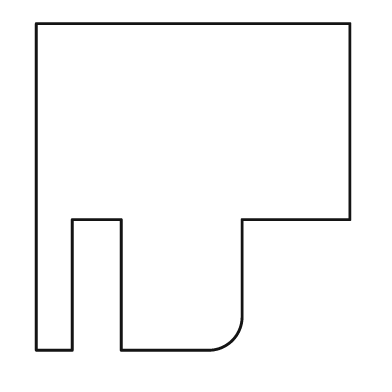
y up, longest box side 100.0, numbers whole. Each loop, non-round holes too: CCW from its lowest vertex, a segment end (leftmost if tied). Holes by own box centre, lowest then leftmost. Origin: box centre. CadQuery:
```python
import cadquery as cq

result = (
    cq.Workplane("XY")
    .moveTo(-48.0, -50.0)
    .lineTo(-37.0, -50.0)
    .lineTo(-37.0, -10.0)
    .lineTo(-22.0, -10.0)
    .lineTo(-22.0, -50.0)
    .lineTo(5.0, -50.0)
    .threePointArc((12.0, -47.0), (15.0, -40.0))
    .lineTo(15.0, -10.0)
    .lineTo(48.0, -10.0)
    .lineTo(48.0, 50.0)
    .lineTo(-48.0, 50.0)
    .close()
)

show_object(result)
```